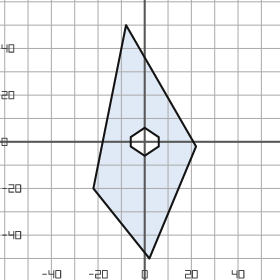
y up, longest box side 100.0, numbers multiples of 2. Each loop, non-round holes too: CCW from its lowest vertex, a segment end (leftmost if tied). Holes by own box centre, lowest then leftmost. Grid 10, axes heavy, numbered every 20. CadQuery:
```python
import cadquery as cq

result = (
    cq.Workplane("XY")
    .moveTo(2.0, -50.0)
    .lineTo(22.0, -2.0)
    .lineTo(-8.0, 50.0)
    .lineTo(-22.0, -20.0)
    .close()
    .moveTo(0.0, -6.0)
    .lineTo(6.0, -2.0)
    .lineTo(6.0, 2.0)
    .lineTo(0.0, 6.0)
    .lineTo(-6.0, 2.0)
    .lineTo(-6.0, -2.0)
    .close()
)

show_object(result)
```